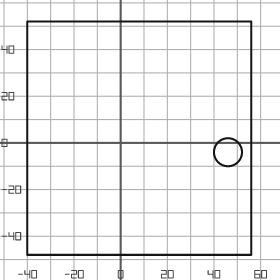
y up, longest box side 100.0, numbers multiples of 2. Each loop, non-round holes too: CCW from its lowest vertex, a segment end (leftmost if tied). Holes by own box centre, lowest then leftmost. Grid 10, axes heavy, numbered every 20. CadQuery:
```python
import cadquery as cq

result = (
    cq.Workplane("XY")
    .moveTo(-40.0, -48.0)
    .lineTo(56.0, -48.0)
    .lineTo(56.0, 52.0)
    .lineTo(-40.0, 52.0)
    .close()
    .moveTo(46.0, -4.0)
    .circle(6.0)
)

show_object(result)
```